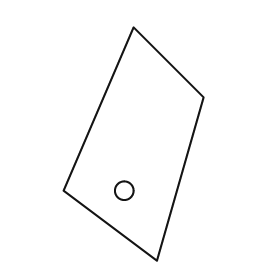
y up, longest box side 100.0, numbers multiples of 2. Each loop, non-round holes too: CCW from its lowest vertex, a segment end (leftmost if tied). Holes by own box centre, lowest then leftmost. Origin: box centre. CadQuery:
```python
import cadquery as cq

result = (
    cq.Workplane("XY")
    .moveTo(10.0, -50.0)
    .lineTo(30.0, 20.0)
    .lineTo(0.0, 50.0)
    .lineTo(-30.0, -20.0)
    .close()
    .moveTo(-4.0, -20.0)
    .circle(4.0)
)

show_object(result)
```